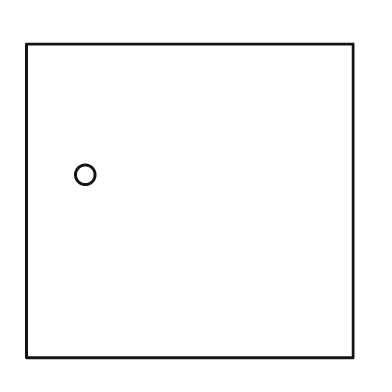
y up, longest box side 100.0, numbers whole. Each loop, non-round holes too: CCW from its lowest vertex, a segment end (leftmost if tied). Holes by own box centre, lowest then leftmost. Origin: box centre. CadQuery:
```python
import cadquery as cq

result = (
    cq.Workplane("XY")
    .moveTo(-50.0, -48.0)
    .lineTo(50.0, -48.0)
    .lineTo(50.0, 48.0)
    .lineTo(-50.0, 48.0)
    .close()
    .moveTo(-32.0, 8.0)
    .circle(3.0)
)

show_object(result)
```